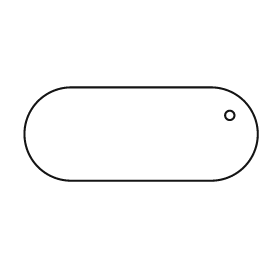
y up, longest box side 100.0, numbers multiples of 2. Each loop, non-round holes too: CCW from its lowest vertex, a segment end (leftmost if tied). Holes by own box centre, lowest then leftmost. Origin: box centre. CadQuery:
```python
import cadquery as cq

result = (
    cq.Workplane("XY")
    .moveTo(-30.0, -20.0)
    .lineTo(30.0, -20.0)
    .threePointArc((50.0, 0.0), (30.0, 20.0))
    .lineTo(-30.0, 20.0)
    .threePointArc((-50.0, 0.0), (-30.0, -20.0))
    .close()
    .moveTo(38.0, 8.0)
    .circle(2.0)
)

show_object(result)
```